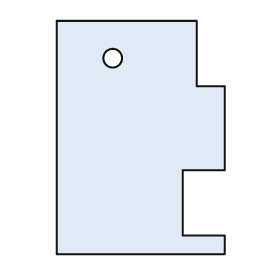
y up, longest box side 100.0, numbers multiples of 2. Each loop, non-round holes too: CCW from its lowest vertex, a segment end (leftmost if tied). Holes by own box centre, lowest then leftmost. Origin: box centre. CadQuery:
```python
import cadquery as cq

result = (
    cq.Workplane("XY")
    .moveTo(-36.0, -50.0)
    .lineTo(36.0, -50.0)
    .lineTo(36.0, -42.0)
    .lineTo(18.0, -42.0)
    .lineTo(18.0, -14.0)
    .lineTo(36.0, -14.0)
    .lineTo(36.0, 22.0)
    .lineTo(24.0, 22.0)
    .lineTo(24.0, 50.0)
    .lineTo(-36.0, 50.0)
    .close()
    .moveTo(-12.0, 34.0)
    .circle(4.0)
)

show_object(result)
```